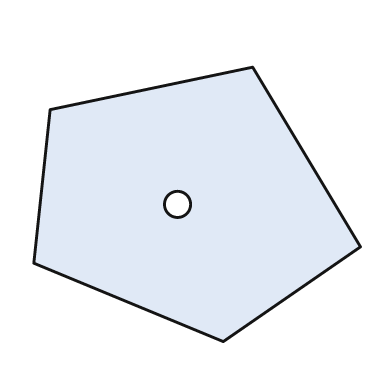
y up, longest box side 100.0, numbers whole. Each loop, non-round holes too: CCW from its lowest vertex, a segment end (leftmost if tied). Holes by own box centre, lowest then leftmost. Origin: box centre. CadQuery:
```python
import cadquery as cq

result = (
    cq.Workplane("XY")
    .moveTo(8.0, -42.0)
    .lineTo(50.0, -13.0)
    .lineTo(17.0, 42.0)
    .lineTo(-45.0, 29.0)
    .lineTo(-50.0, -18.0)
    .close()
    .moveTo(-6.0, 0.0)
    .circle(4.0)
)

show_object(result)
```